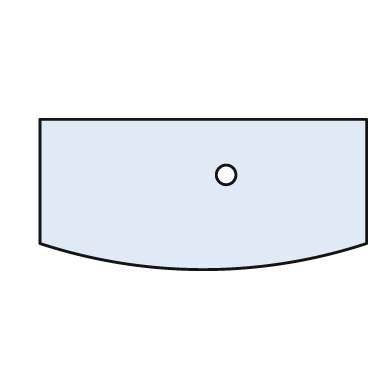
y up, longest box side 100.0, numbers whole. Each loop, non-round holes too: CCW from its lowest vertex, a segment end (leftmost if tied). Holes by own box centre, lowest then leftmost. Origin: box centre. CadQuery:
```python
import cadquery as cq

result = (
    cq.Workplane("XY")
    .moveTo(-50.0, -15.0)
    .threePointArc((0.0, -23.0), (50.0, -15.0))
    .lineTo(50.0, 23.0)
    .lineTo(-50.0, 23.0)
    .close()
    .moveTo(7.0, 6.0)
    .circle(3.0)
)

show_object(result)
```